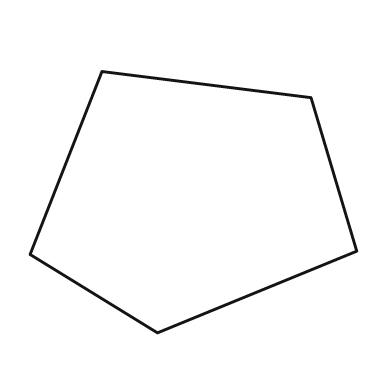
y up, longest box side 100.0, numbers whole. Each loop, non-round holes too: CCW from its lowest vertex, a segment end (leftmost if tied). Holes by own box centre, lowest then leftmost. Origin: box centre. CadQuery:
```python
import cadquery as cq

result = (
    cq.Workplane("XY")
    .moveTo(-11.0, -40.0)
    .lineTo(50.0, -15.0)
    .lineTo(36.0, 32.0)
    .lineTo(-28.0, 40.0)
    .lineTo(-50.0, -16.0)
    .close()
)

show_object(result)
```